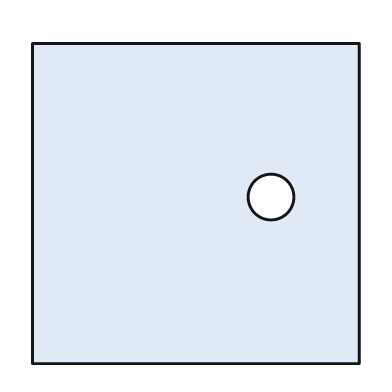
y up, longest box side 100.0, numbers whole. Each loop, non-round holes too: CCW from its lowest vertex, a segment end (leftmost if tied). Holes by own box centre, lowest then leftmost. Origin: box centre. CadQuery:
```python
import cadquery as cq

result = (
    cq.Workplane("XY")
    .moveTo(-50.0, -49.0)
    .lineTo(50.0, -49.0)
    .lineTo(50.0, 49.0)
    .lineTo(-50.0, 49.0)
    .close()
    .moveTo(23.0, 2.0)
    .circle(7.0)
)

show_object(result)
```